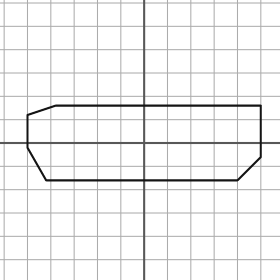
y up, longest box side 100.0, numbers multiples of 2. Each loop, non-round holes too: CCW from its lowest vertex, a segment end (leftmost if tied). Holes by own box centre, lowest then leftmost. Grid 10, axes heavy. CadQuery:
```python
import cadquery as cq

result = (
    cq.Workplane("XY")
    .moveTo(-42.0, -16.0)
    .lineTo(40.0, -16.0)
    .lineTo(50.0, -6.0)
    .lineTo(50.0, 16.0)
    .lineTo(-38.0, 16.0)
    .lineTo(-50.0, 12.0)
    .lineTo(-50.0, -2.0)
    .close()
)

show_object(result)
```